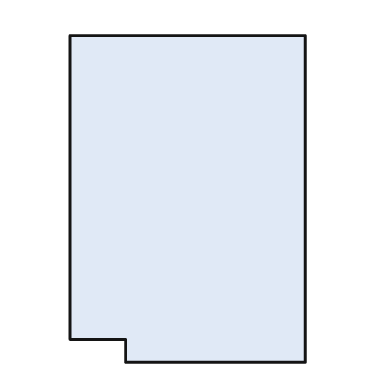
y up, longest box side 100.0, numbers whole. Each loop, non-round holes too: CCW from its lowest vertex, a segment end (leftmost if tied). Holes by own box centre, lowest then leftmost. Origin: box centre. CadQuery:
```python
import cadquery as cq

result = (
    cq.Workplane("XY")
    .moveTo(-19.0, -50.0)
    .lineTo(36.0, -50.0)
    .lineTo(36.0, 50.0)
    .lineTo(-36.0, 50.0)
    .lineTo(-36.0, -43.0)
    .lineTo(-19.0, -43.0)
    .close()
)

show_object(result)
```